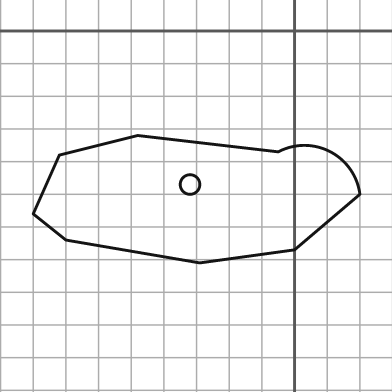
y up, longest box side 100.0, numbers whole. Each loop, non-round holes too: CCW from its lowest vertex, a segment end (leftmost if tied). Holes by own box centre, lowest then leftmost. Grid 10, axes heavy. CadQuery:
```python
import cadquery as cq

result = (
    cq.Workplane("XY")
    .moveTo(-29.0, -71.0)
    .lineTo(0.0, -67.0)
    .lineTo(20.0, -50.0)
    .threePointArc((11.0, -37.0), (-5.0, -37.0))
    .lineTo(-48.0, -32.0)
    .lineTo(-72.0, -38.0)
    .lineTo(-80.0, -56.0)
    .lineTo(-70.0, -64.0)
    .close()
    .moveTo(-32.0, -47.0)
    .circle(3.0)
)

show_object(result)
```